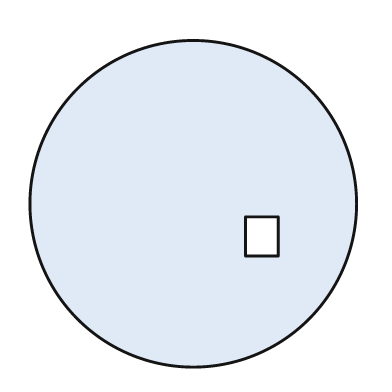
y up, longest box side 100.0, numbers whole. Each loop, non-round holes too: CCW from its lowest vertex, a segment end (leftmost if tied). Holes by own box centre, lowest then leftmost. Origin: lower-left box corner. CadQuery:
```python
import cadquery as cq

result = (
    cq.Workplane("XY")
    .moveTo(50.0, 50.0)
    .circle(50.0)
    .moveTo(66.0, 34.0)
    .lineTo(76.0, 34.0)
    .lineTo(76.0, 46.0)
    .lineTo(66.0, 46.0)
    .close()
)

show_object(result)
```